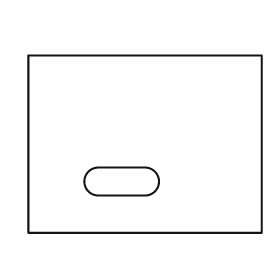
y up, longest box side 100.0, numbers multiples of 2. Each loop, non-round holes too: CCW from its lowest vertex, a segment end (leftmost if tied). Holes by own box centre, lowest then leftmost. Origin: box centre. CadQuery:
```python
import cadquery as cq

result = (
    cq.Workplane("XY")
    .moveTo(-50.0, -38.0)
    .lineTo(50.0, -38.0)
    .lineTo(50.0, 38.0)
    .lineTo(-50.0, 38.0)
    .close()
    .moveTo(-20.0, -22.0)
    .lineTo(0.0, -22.0)
    .threePointArc((6.0, -16.0), (0.0, -10.0))
    .lineTo(-20.0, -10.0)
    .threePointArc((-26.0, -16.0), (-20.0, -22.0))
    .close()
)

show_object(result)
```